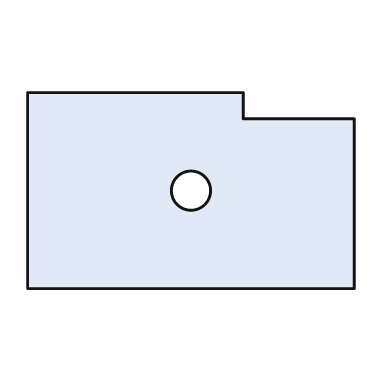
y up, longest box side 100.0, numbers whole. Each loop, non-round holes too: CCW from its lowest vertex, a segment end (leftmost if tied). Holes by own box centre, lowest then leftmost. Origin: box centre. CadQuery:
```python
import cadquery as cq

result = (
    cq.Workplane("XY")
    .moveTo(-50.0, -30.0)
    .lineTo(50.0, -30.0)
    .lineTo(50.0, 22.0)
    .lineTo(16.0, 22.0)
    .lineTo(16.0, 30.0)
    .lineTo(-50.0, 30.0)
    .close()
    .moveTo(0.0, 0.0)
    .circle(6.0)
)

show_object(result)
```